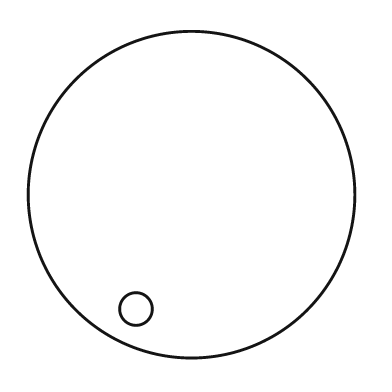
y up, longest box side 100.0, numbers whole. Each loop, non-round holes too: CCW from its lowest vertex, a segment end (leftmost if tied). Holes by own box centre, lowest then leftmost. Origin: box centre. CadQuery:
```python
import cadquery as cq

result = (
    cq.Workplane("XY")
    .moveTo(0.0, 0.0)
    .circle(50.0)
    .moveTo(-17.0, -35.0)
    .circle(5.0)
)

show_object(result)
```